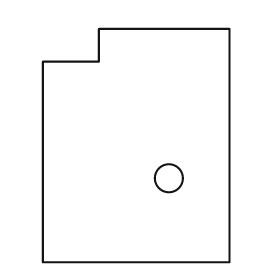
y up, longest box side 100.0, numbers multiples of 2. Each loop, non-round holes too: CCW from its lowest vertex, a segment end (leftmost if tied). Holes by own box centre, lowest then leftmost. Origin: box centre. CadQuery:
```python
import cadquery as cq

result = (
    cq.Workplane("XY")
    .moveTo(-40.0, -50.0)
    .lineTo(40.0, -50.0)
    .lineTo(40.0, 50.0)
    .lineTo(-16.0, 50.0)
    .lineTo(-16.0, 36.0)
    .lineTo(-40.0, 36.0)
    .close()
    .moveTo(14.0, -14.0)
    .circle(6.0)
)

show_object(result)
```